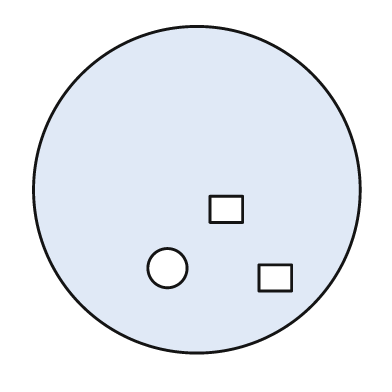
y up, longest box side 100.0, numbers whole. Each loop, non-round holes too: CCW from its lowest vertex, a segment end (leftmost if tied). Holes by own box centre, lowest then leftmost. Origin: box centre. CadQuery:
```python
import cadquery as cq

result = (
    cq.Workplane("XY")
    .moveTo(0.0, 0.0)
    .circle(50.0)
    .moveTo(19.0, -31.0)
    .lineTo(29.0, -31.0)
    .lineTo(29.0, -23.0)
    .lineTo(19.0, -23.0)
    .close()
    .moveTo(-9.0, -24.0)
    .circle(6.0)
    .moveTo(4.0, -10.0)
    .lineTo(14.0, -10.0)
    .lineTo(14.0, -2.0)
    .lineTo(4.0, -2.0)
    .close()
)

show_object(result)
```